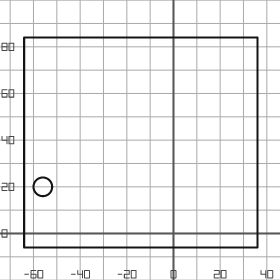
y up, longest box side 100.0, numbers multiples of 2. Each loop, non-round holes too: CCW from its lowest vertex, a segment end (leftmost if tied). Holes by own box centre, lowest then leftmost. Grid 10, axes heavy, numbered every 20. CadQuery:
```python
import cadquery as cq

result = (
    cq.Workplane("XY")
    .moveTo(-64.0, -6.0)
    .lineTo(36.0, -6.0)
    .lineTo(36.0, 84.0)
    .lineTo(-64.0, 84.0)
    .close()
    .moveTo(-56.0, 20.0)
    .circle(4.0)
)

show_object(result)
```